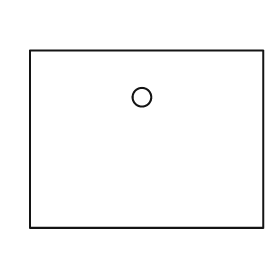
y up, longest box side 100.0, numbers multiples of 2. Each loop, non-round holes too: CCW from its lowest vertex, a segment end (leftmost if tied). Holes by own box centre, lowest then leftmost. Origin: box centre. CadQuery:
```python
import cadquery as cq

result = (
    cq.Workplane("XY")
    .moveTo(-50.0, -38.0)
    .lineTo(50.0, -38.0)
    .lineTo(50.0, 38.0)
    .lineTo(-50.0, 38.0)
    .close()
    .moveTo(-2.0, 18.0)
    .circle(4.0)
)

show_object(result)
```